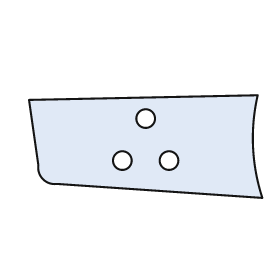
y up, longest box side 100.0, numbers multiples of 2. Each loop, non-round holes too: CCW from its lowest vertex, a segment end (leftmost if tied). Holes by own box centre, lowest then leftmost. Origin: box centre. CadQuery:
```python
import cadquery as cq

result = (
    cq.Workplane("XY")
    .moveTo(50.0, -22.0)
    .threePointArc((46.0, 0.0), (48.0, 22.0))
    .lineTo(-50.0, 20.0)
    .lineTo(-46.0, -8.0)
    .threePointArc((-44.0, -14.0), (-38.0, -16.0))
    .close()
    .moveTo(-10.0, -6.0)
    .circle(4.0)
    .moveTo(10.0, -6.0)
    .circle(4.0)
    .moveTo(0.0, 12.0)
    .circle(4.0)
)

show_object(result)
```